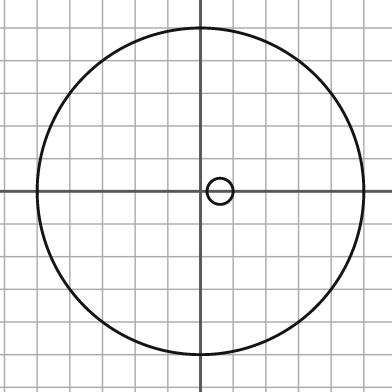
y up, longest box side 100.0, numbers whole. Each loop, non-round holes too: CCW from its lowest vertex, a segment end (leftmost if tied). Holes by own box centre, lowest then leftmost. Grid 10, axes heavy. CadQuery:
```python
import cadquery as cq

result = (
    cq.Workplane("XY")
    .moveTo(0.0, 0.0)
    .circle(50.0)
    .moveTo(6.0, 0.0)
    .circle(4.0)
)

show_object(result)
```